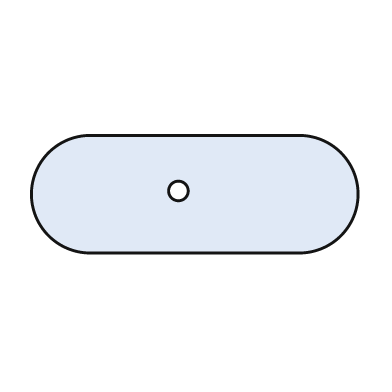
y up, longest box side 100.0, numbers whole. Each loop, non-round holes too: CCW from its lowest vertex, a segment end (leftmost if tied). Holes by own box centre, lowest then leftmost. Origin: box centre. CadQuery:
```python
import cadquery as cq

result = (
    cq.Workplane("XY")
    .moveTo(-32.0, -18.0)
    .lineTo(32.0, -18.0)
    .threePointArc((50.0, 0.0), (32.0, 18.0))
    .lineTo(-32.0, 18.0)
    .threePointArc((-50.0, 0.0), (-32.0, -18.0))
    .close()
    .moveTo(-5.0, 1.0)
    .circle(3.0)
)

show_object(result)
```